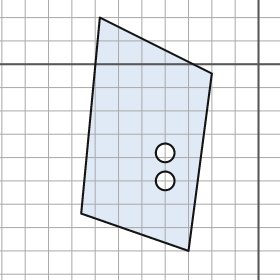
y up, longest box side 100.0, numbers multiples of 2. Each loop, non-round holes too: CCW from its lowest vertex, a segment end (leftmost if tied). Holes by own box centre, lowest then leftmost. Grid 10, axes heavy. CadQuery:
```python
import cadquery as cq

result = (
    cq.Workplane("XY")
    .moveTo(-30.0, -80.0)
    .lineTo(-20.0, -4.0)
    .lineTo(-68.0, 20.0)
    .lineTo(-76.0, -64.0)
    .close()
    .moveTo(-40.0, -50.0)
    .circle(4.0)
    .moveTo(-40.0, -38.0)
    .circle(4.0)
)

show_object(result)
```